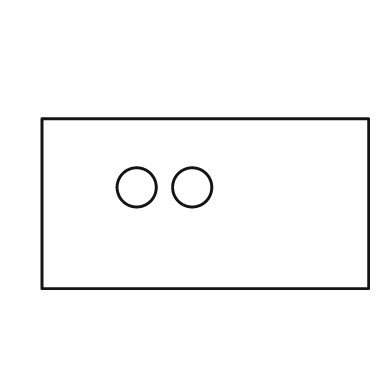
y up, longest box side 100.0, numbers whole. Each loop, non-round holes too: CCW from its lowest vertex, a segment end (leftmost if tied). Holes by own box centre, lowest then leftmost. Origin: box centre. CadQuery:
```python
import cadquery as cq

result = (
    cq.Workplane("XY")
    .moveTo(-50.0, -26.0)
    .lineTo(50.0, -26.0)
    .lineTo(50.0, 26.0)
    .lineTo(-50.0, 26.0)
    .close()
    .moveTo(-21.0, 5.0)
    .circle(6.0)
    .moveTo(-4.0, 5.0)
    .circle(6.0)
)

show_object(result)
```